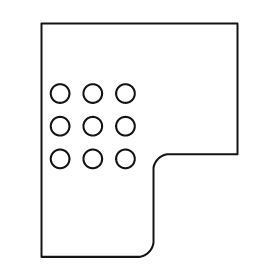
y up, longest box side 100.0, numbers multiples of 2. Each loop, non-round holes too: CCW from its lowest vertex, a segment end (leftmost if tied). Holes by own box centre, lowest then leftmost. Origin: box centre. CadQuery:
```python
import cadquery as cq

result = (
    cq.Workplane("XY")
    .moveTo(-42.0, -50.0)
    .lineTo(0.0, -50.0)
    .threePointArc((4.0, -48.0), (6.0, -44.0))
    .lineTo(6.0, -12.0)
    .threePointArc((8.0, -8.0), (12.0, -6.0))
    .lineTo(42.0, -6.0)
    .lineTo(42.0, 50.0)
    .lineTo(-42.0, 50.0)
    .close()
    .moveTo(-34.0, -8.0)
    .circle(4.0)
    .moveTo(-20.0, -8.0)
    .circle(4.0)
    .moveTo(-6.0, -8.0)
    .circle(4.0)
    .moveTo(-34.0, 6.0)
    .circle(4.0)
    .moveTo(-20.0, 6.0)
    .circle(4.0)
    .moveTo(-6.0, 6.0)
    .circle(4.0)
    .moveTo(-34.0, 20.0)
    .circle(4.0)
    .moveTo(-20.0, 20.0)
    .circle(4.0)
    .moveTo(-6.0, 20.0)
    .circle(4.0)
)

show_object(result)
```